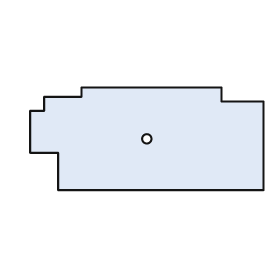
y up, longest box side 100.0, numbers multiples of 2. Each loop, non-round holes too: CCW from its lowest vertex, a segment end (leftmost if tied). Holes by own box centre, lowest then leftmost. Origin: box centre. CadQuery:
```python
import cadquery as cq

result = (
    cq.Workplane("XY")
    .moveTo(-38.0, -22.0)
    .lineTo(50.0, -22.0)
    .lineTo(50.0, 16.0)
    .lineTo(32.0, 16.0)
    .lineTo(32.0, 22.0)
    .lineTo(-28.0, 22.0)
    .lineTo(-28.0, 18.0)
    .lineTo(-44.0, 18.0)
    .lineTo(-44.0, 12.0)
    .lineTo(-50.0, 12.0)
    .lineTo(-50.0, -6.0)
    .lineTo(-38.0, -6.0)
    .close()
    .moveTo(0.0, 0.0)
    .circle(2.0)
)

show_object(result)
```